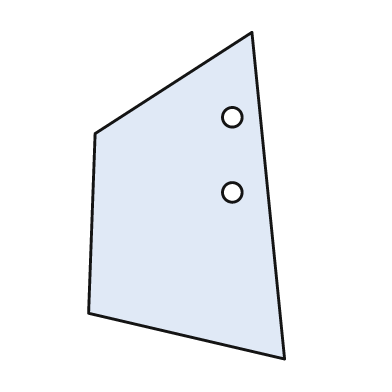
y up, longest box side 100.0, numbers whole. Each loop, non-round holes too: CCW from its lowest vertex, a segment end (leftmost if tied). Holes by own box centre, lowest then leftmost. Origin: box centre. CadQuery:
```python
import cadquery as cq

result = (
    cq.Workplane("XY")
    .moveTo(30.0, -50.0)
    .lineTo(20.0, 50.0)
    .lineTo(-28.0, 19.0)
    .lineTo(-30.0, -36.0)
    .close()
    .moveTo(14.0, 1.0)
    .circle(3.0)
    .moveTo(14.0, 24.0)
    .circle(3.0)
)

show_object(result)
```